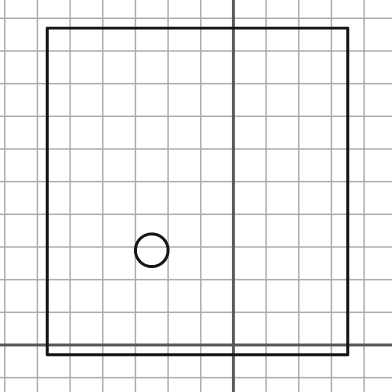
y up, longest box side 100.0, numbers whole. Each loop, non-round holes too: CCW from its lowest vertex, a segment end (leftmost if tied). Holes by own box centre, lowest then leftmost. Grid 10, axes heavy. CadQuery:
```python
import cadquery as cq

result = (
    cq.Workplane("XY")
    .moveTo(-57.0, -3.0)
    .lineTo(35.0, -3.0)
    .lineTo(35.0, 97.0)
    .lineTo(-57.0, 97.0)
    .close()
    .moveTo(-25.0, 29.0)
    .circle(5.0)
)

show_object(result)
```